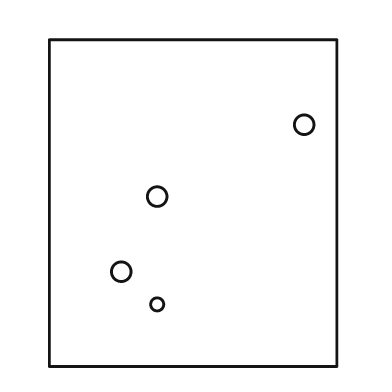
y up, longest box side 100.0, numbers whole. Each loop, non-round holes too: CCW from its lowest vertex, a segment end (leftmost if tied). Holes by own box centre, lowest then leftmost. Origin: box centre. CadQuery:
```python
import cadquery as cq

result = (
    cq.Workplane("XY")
    .moveTo(-44.0, -50.0)
    .lineTo(44.0, -50.0)
    .lineTo(44.0, 50.0)
    .lineTo(-44.0, 50.0)
    .close()
    .moveTo(-11.0, -31.0)
    .circle(2.0)
    .moveTo(-22.0, -21.0)
    .circle(3.0)
    .moveTo(-11.0, 2.0)
    .circle(3.0)
    .moveTo(34.0, 24.0)
    .circle(3.0)
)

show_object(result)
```